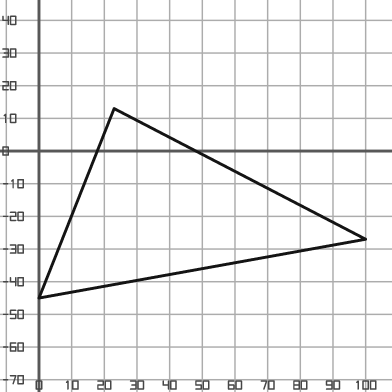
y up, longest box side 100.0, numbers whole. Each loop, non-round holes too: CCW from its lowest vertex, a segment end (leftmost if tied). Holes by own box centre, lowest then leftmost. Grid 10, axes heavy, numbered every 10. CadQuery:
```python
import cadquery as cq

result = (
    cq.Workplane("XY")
    .moveTo(0.0, -45.0)
    .lineTo(100.0, -27.0)
    .lineTo(23.0, 13.0)
    .close()
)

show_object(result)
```